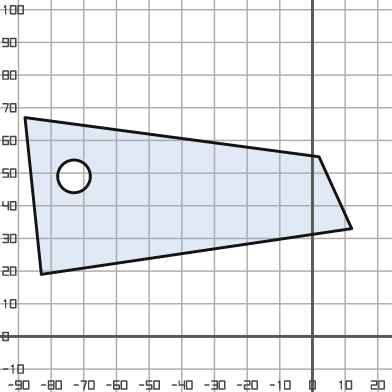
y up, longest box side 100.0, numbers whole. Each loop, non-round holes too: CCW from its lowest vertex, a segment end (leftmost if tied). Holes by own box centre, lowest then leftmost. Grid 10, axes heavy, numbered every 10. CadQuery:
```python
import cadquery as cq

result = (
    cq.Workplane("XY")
    .moveTo(-83.0, 19.0)
    .lineTo(12.0, 33.0)
    .lineTo(2.0, 55.0)
    .lineTo(-88.0, 67.0)
    .close()
    .moveTo(-73.0, 49.0)
    .circle(5.0)
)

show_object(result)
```